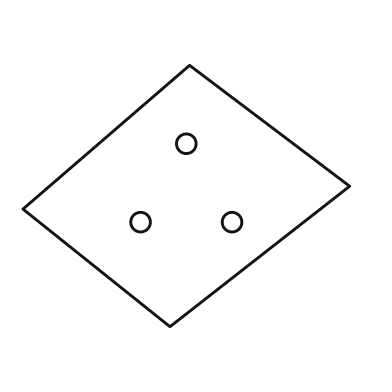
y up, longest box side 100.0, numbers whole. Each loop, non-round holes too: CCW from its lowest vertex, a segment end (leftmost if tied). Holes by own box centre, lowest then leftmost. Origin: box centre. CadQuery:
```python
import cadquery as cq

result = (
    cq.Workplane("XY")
    .moveTo(-5.0, -40.0)
    .lineTo(50.0, 3.0)
    .lineTo(1.0, 40.0)
    .lineTo(-50.0, -4.0)
    .close()
    .moveTo(-14.0, -8.0)
    .circle(3.0)
    .moveTo(14.0, -8.0)
    .circle(3.0)
    .moveTo(0.0, 16.0)
    .circle(3.0)
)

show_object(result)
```